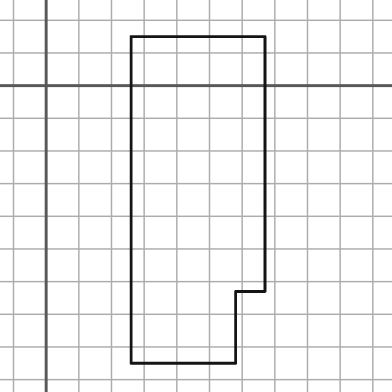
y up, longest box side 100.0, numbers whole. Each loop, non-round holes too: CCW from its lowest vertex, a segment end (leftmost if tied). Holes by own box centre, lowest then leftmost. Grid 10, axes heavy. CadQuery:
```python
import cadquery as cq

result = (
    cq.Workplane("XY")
    .moveTo(26.0, -85.0)
    .lineTo(58.0, -85.0)
    .lineTo(58.0, -63.0)
    .lineTo(67.0, -63.0)
    .lineTo(67.0, 15.0)
    .lineTo(26.0, 15.0)
    .close()
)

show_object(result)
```